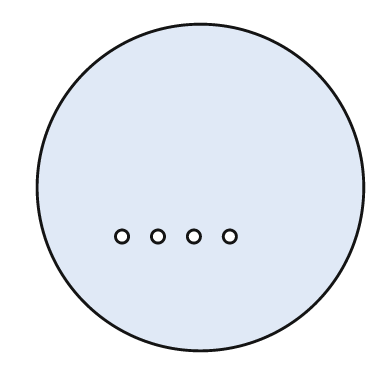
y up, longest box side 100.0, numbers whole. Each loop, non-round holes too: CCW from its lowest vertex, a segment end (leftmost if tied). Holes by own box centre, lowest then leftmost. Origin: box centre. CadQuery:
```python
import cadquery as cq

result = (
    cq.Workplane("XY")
    .moveTo(0.0, 0.0)
    .circle(50.0)
    .moveTo(-24.0, -15.0)
    .circle(2.0)
    .moveTo(-13.0, -15.0)
    .circle(2.0)
    .moveTo(-2.0, -15.0)
    .circle(2.0)
    .moveTo(9.0, -15.0)
    .circle(2.0)
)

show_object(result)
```